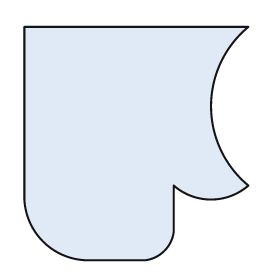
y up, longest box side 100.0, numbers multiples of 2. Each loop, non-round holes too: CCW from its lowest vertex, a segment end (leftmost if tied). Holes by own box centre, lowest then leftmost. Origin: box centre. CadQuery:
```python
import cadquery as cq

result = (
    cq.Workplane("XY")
    .moveTo(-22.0, -50.0)
    .lineTo(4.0, -50.0)
    .threePointArc((12.0, -46.0), (16.0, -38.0))
    .lineTo(16.0, -18.0)
    .threePointArc((32.0, -24.0), (48.0, -18.0))
    .threePointArc((32.0, 16.0), (48.0, 50.0))
    .lineTo(-48.0, 50.0)
    .lineTo(-48.0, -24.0)
    .threePointArc((-40.0, -42.0), (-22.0, -50.0))
    .close()
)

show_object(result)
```